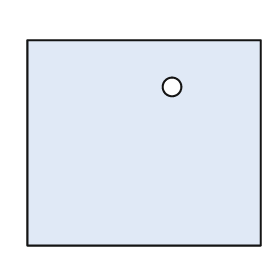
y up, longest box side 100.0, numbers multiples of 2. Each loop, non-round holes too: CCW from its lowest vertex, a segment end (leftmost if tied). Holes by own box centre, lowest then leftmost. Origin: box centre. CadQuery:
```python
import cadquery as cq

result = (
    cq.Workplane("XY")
    .moveTo(-50.0, -44.0)
    .lineTo(50.0, -44.0)
    .lineTo(50.0, 44.0)
    .lineTo(-50.0, 44.0)
    .close()
    .moveTo(12.0, 24.0)
    .circle(4.0)
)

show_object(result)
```